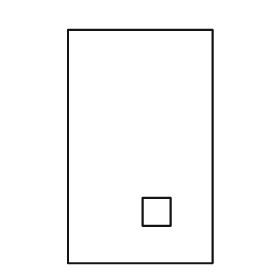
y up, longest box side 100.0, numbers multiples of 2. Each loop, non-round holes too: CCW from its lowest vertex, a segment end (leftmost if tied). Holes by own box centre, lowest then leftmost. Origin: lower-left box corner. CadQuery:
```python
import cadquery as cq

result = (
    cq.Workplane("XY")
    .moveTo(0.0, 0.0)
    .lineTo(62.0, 0.0)
    .lineTo(62.0, 100.0)
    .lineTo(0.0, 100.0)
    .close()
    .moveTo(32.0, 16.0)
    .lineTo(44.0, 16.0)
    .lineTo(44.0, 28.0)
    .lineTo(32.0, 28.0)
    .close()
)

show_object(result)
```